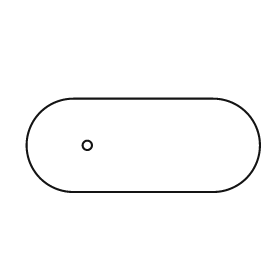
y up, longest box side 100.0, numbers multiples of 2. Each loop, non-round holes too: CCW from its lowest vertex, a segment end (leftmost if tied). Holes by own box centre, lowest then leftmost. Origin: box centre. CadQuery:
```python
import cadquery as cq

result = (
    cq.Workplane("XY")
    .moveTo(-30.0, -20.0)
    .lineTo(30.0, -20.0)
    .threePointArc((50.0, 0.0), (30.0, 20.0))
    .lineTo(-30.0, 20.0)
    .threePointArc((-50.0, 0.0), (-30.0, -20.0))
    .close()
    .moveTo(-24.0, 0.0)
    .circle(2.0)
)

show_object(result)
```